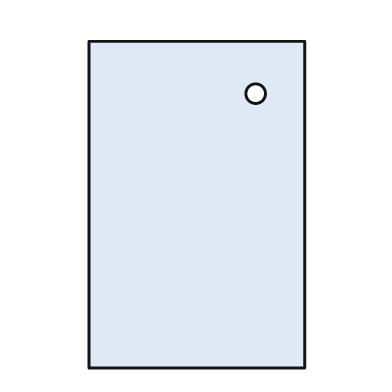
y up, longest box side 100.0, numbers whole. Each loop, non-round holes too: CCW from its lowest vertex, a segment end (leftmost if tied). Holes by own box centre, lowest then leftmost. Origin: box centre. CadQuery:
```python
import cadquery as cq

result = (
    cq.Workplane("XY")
    .moveTo(-33.0, -50.0)
    .lineTo(33.0, -50.0)
    .lineTo(33.0, 50.0)
    .lineTo(-33.0, 50.0)
    .close()
    .moveTo(18.0, 34.0)
    .circle(3.0)
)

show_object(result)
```